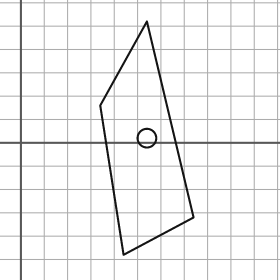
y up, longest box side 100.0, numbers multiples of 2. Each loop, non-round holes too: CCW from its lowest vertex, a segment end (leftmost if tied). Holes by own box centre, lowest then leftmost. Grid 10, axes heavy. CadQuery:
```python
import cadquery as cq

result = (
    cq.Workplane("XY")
    .moveTo(44.0, -48.0)
    .lineTo(74.0, -32.0)
    .lineTo(54.0, 52.0)
    .lineTo(34.0, 16.0)
    .close()
    .moveTo(54.0, 2.0)
    .circle(4.0)
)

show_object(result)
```